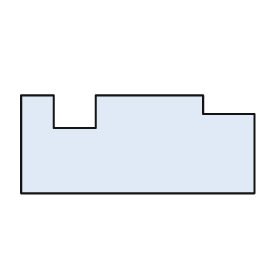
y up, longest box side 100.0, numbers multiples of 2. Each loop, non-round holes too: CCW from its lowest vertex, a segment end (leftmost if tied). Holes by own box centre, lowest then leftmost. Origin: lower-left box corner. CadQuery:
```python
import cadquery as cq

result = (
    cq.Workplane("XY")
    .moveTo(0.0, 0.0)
    .lineTo(100.0, 0.0)
    .lineTo(100.0, 34.0)
    .lineTo(78.0, 34.0)
    .lineTo(78.0, 42.0)
    .lineTo(32.0, 42.0)
    .lineTo(32.0, 28.0)
    .lineTo(14.0, 28.0)
    .lineTo(14.0, 42.0)
    .lineTo(0.0, 42.0)
    .close()
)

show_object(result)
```